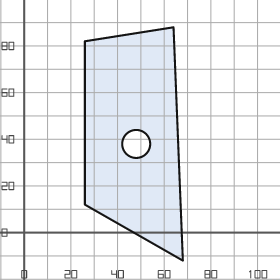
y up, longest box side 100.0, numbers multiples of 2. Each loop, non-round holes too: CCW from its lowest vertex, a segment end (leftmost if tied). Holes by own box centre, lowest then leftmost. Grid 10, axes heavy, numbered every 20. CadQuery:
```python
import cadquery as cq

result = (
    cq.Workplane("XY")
    .moveTo(68.0, -12.0)
    .lineTo(64.0, 88.0)
    .lineTo(26.0, 82.0)
    .lineTo(26.0, 12.0)
    .close()
    .moveTo(48.0, 38.0)
    .circle(6.0)
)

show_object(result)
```